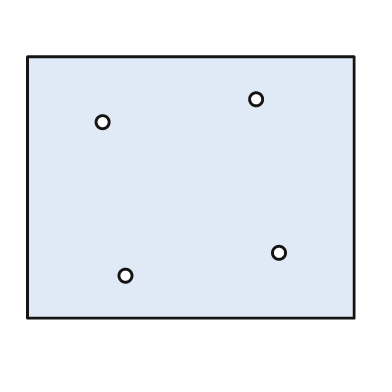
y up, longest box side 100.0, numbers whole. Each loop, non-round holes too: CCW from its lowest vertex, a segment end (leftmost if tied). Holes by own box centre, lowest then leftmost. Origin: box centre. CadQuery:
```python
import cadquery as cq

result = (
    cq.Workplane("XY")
    .moveTo(-50.0, -40.0)
    .lineTo(50.0, -40.0)
    .lineTo(50.0, 40.0)
    .lineTo(-50.0, 40.0)
    .close()
    .moveTo(-20.0, -27.0)
    .circle(2.0)
    .moveTo(27.0, -20.0)
    .circle(2.0)
    .moveTo(-27.0, 20.0)
    .circle(2.0)
    .moveTo(20.0, 27.0)
    .circle(2.0)
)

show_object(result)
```